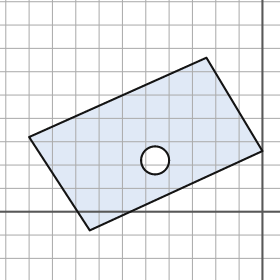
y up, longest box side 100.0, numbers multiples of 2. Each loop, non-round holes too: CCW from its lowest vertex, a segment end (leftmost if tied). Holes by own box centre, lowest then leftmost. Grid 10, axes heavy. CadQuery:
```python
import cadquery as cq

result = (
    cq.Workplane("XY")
    .moveTo(-74.0, -8.0)
    .lineTo(0.0, 26.0)
    .lineTo(-24.0, 66.0)
    .lineTo(-100.0, 32.0)
    .close()
    .moveTo(-46.0, 22.0)
    .circle(6.0)
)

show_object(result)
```